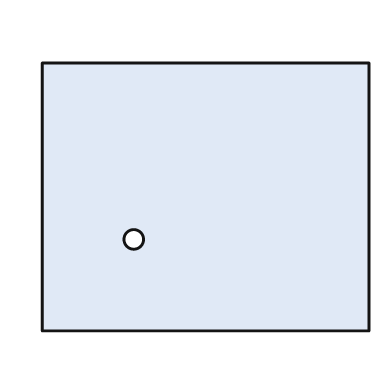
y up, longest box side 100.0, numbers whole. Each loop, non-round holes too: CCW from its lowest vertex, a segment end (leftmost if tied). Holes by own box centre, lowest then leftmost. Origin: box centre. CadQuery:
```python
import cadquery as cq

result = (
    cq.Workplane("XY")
    .moveTo(-50.0, -41.0)
    .lineTo(50.0, -41.0)
    .lineTo(50.0, 41.0)
    .lineTo(-50.0, 41.0)
    .close()
    .moveTo(-22.0, -13.0)
    .circle(3.0)
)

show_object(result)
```